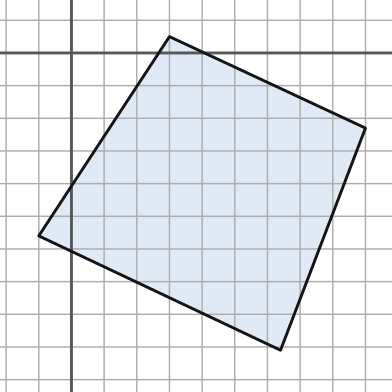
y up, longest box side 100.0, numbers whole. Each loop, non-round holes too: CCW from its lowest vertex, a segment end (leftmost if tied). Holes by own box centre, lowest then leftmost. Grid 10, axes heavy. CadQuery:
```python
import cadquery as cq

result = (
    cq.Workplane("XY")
    .moveTo(64.0, -91.0)
    .lineTo(90.0, -23.0)
    .lineTo(30.0, 5.0)
    .lineTo(-10.0, -56.0)
    .close()
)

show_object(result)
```